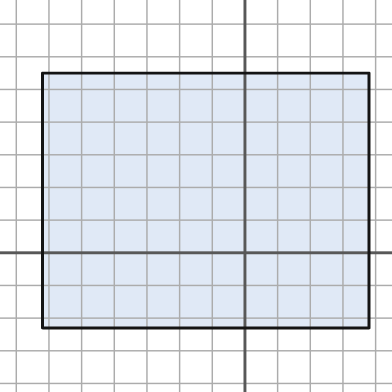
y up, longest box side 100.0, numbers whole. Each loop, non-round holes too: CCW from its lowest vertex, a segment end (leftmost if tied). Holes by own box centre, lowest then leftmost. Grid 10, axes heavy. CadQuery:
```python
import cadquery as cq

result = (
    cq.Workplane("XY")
    .moveTo(-62.0, -23.0)
    .lineTo(38.0, -23.0)
    .lineTo(38.0, 55.0)
    .lineTo(-62.0, 55.0)
    .close()
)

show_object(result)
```